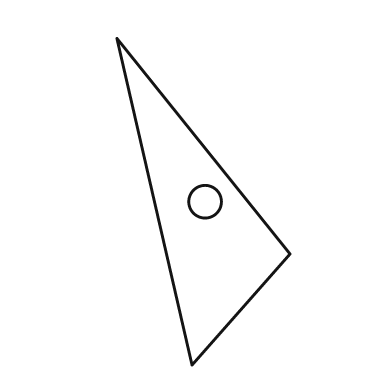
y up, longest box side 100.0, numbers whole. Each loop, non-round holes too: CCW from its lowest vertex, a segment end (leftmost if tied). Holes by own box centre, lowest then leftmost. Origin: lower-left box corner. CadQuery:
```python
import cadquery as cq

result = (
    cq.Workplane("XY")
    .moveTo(23.0, 0.0)
    .lineTo(53.0, 34.0)
    .lineTo(0.0, 100.0)
    .close()
    .moveTo(27.0, 50.0)
    .circle(5.0)
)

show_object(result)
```